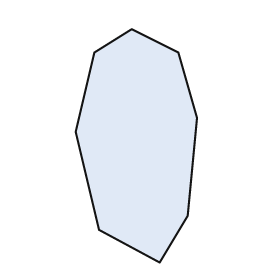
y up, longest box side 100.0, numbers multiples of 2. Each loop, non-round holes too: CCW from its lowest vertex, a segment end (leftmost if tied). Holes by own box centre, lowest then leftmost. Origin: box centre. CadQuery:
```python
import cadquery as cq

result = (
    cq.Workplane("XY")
    .moveTo(10.0, -50.0)
    .lineTo(22.0, -30.0)
    .lineTo(26.0, 12.0)
    .lineTo(18.0, 40.0)
    .lineTo(-2.0, 50.0)
    .lineTo(-18.0, 40.0)
    .lineTo(-26.0, 6.0)
    .lineTo(-16.0, -36.0)
    .close()
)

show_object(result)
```